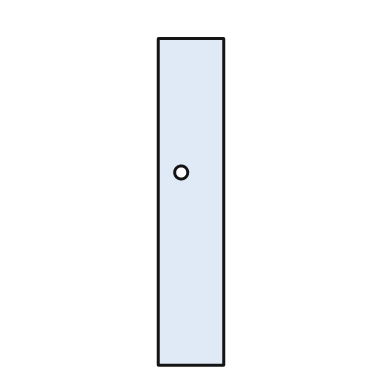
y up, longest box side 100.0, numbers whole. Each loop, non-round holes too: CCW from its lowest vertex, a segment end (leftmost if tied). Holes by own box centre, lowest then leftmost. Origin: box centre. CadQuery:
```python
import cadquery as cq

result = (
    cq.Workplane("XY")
    .moveTo(-10.0, -50.0)
    .lineTo(10.0, -50.0)
    .lineTo(10.0, 50.0)
    .lineTo(-10.0, 50.0)
    .close()
    .moveTo(-3.0, 9.0)
    .circle(2.0)
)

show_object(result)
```